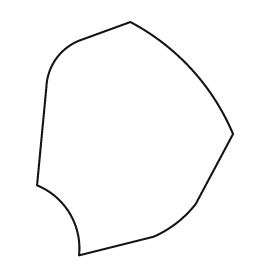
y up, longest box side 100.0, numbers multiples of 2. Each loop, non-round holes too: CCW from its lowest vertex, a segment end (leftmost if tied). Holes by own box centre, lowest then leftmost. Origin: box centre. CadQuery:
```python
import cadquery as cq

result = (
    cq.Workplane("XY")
    .moveTo(-24.0, -50.0)
    .lineTo(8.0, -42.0)
    .threePointArc((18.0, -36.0), (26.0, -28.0))
    .lineTo(42.0, 2.0)
    .threePointArc((24.0, 30.0), (-2.0, 50.0))
    .lineTo(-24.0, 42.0)
    .threePointArc((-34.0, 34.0), (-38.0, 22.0))
    .lineTo(-42.0, -20.0)
    .threePointArc((-28.0, -32.0), (-24.0, -50.0))
    .close()
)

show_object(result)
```